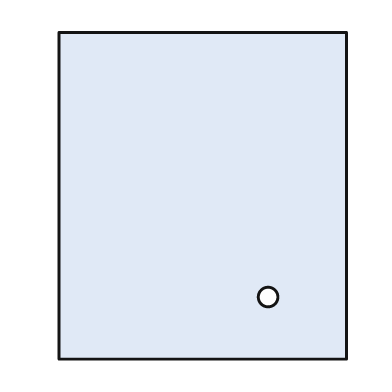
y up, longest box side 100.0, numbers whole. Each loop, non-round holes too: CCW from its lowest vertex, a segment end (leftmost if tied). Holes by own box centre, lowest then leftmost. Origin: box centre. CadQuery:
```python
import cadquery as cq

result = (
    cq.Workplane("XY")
    .moveTo(-44.0, -50.0)
    .lineTo(44.0, -50.0)
    .lineTo(44.0, 50.0)
    .lineTo(-44.0, 50.0)
    .close()
    .moveTo(20.0, -31.0)
    .circle(3.0)
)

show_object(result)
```